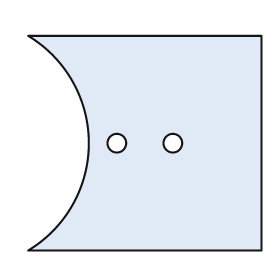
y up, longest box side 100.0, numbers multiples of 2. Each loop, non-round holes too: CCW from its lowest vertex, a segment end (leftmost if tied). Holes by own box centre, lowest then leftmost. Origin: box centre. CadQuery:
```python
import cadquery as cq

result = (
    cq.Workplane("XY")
    .moveTo(-50.0, -46.0)
    .lineTo(50.0, -46.0)
    .lineTo(50.0, 46.0)
    .lineTo(-50.0, 46.0)
    .threePointArc((-24.0, 0.0), (-50.0, -46.0))
    .close()
    .moveTo(-12.0, 0.0)
    .circle(4.0)
    .moveTo(12.0, 0.0)
    .circle(4.0)
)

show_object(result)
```